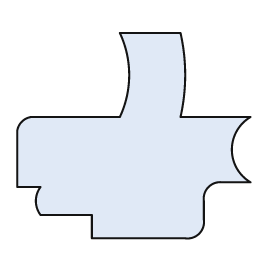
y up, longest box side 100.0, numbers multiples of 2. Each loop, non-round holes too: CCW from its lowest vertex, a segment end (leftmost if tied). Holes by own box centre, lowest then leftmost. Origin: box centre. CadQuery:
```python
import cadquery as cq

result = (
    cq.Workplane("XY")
    .moveTo(-18.0, -44.0)
    .lineTo(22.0, -44.0)
    .threePointArc((28.0, -42.0), (30.0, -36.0))
    .lineTo(30.0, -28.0)
    .threePointArc((32.0, -22.0), (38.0, -20.0))
    .lineTo(50.0, -20.0)
    .threePointArc((42.0, -6.0), (50.0, 8.0))
    .lineTo(20.0, 8.0)
    .threePointArc((22.0, 26.0), (20.0, 44.0))
    .lineTo(-6.0, 44.0)
    .threePointArc((-2.0, 26.0), (-6.0, 8.0))
    .lineTo(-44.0, 8.0)
    .threePointArc((-48.0, 6.0), (-50.0, 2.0))
    .lineTo(-50.0, -22.0)
    .lineTo(-40.0, -22.0)
    .threePointArc((-42.0, -28.0), (-40.0, -34.0))
    .lineTo(-18.0, -34.0)
    .close()
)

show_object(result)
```